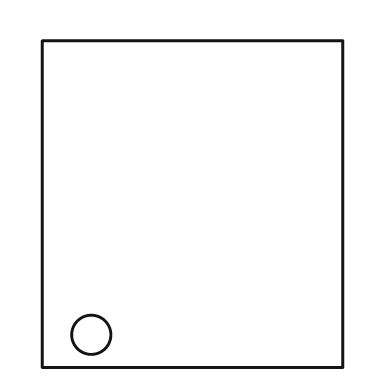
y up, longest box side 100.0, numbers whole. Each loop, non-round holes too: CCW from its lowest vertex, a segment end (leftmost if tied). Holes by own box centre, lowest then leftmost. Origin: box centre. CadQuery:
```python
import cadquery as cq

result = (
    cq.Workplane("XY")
    .moveTo(-46.0, -50.0)
    .lineTo(46.0, -50.0)
    .lineTo(46.0, 50.0)
    .lineTo(-46.0, 50.0)
    .close()
    .moveTo(-31.0, -40.0)
    .circle(6.0)
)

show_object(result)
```